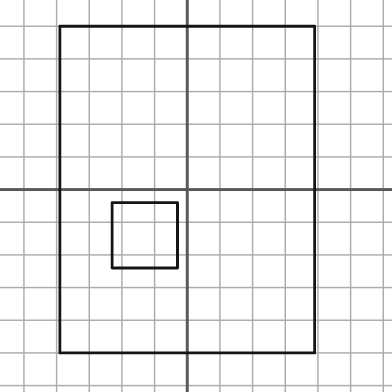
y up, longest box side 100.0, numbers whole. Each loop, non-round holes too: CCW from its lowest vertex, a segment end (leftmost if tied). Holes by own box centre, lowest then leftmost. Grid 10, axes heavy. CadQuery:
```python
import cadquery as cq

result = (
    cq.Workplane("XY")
    .moveTo(-39.0, -50.0)
    .lineTo(39.0, -50.0)
    .lineTo(39.0, 50.0)
    .lineTo(-39.0, 50.0)
    .close()
    .moveTo(-23.0, -24.0)
    .lineTo(-3.0, -24.0)
    .lineTo(-3.0, -4.0)
    .lineTo(-23.0, -4.0)
    .close()
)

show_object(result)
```